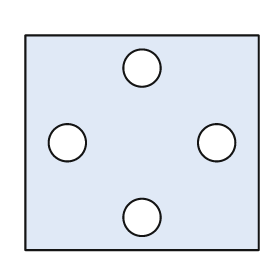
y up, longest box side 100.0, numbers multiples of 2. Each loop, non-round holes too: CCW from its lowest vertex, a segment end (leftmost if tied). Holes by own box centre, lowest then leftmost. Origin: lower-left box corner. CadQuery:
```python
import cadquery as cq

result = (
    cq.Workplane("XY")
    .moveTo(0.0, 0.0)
    .lineTo(100.0, 0.0)
    .lineTo(100.0, 92.0)
    .lineTo(0.0, 92.0)
    .close()
    .moveTo(50.0, 14.0)
    .circle(8.0)
    .moveTo(18.0, 46.0)
    .circle(8.0)
    .moveTo(82.0, 46.0)
    .circle(8.0)
    .moveTo(50.0, 78.0)
    .circle(8.0)
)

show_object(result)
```